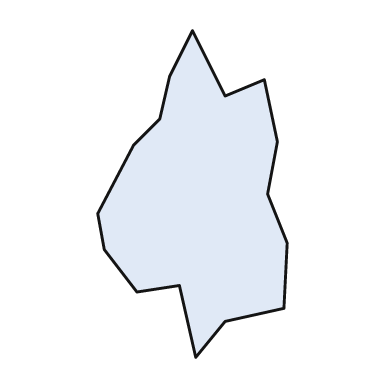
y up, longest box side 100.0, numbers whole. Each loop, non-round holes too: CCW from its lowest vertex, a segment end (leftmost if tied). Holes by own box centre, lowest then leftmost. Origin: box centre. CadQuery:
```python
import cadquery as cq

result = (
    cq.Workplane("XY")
    .moveTo(1.0, -50.0)
    .lineTo(10.0, -39.0)
    .lineTo(28.0, -35.0)
    .lineTo(29.0, -15.0)
    .lineTo(23.0, 0.0)
    .lineTo(26.0, 16.0)
    .lineTo(22.0, 35.0)
    .lineTo(10.0, 30.0)
    .lineTo(0.0, 50.0)
    .lineTo(-7.0, 36.0)
    .lineTo(-10.0, 23.0)
    .lineTo(-18.0, 15.0)
    .lineTo(-29.0, -6.0)
    .lineTo(-27.0, -17.0)
    .lineTo(-17.0, -30.0)
    .lineTo(-4.0, -28.0)
    .close()
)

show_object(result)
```